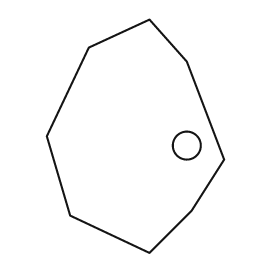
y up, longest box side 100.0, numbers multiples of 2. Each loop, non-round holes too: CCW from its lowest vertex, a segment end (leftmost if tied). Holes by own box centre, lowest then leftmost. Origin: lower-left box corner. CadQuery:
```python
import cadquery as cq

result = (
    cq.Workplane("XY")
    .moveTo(44.0, 0.0)
    .lineTo(62.0, 18.0)
    .lineTo(76.0, 40.0)
    .lineTo(60.0, 82.0)
    .lineTo(44.0, 100.0)
    .lineTo(18.0, 88.0)
    .lineTo(0.0, 50.0)
    .lineTo(10.0, 16.0)
    .close()
    .moveTo(60.0, 46.0)
    .circle(6.0)
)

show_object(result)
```